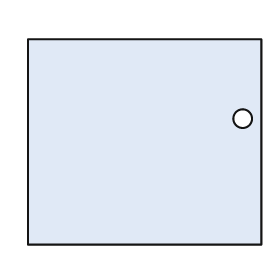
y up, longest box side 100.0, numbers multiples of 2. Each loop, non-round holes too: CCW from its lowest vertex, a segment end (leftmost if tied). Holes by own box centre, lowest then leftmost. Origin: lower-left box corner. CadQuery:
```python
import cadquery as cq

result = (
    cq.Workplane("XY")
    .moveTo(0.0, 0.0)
    .lineTo(100.0, 0.0)
    .lineTo(100.0, 88.0)
    .lineTo(0.0, 88.0)
    .close()
    .moveTo(92.0, 54.0)
    .circle(4.0)
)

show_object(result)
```